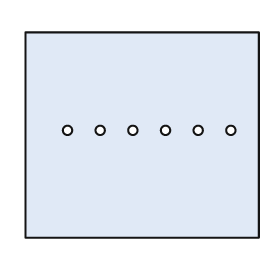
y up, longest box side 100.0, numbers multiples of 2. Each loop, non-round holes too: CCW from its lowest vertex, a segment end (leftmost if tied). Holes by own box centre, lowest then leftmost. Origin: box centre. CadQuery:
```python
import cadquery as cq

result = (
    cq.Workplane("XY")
    .moveTo(-50.0, -44.0)
    .lineTo(50.0, -44.0)
    .lineTo(50.0, 44.0)
    .lineTo(-50.0, 44.0)
    .close()
    .moveTo(-32.0, 2.0)
    .circle(2.0)
    .moveTo(-18.0, 2.0)
    .circle(2.0)
    .moveTo(-4.0, 2.0)
    .circle(2.0)
    .moveTo(10.0, 2.0)
    .circle(2.0)
    .moveTo(24.0, 2.0)
    .circle(2.0)
    .moveTo(38.0, 2.0)
    .circle(2.0)
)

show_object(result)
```